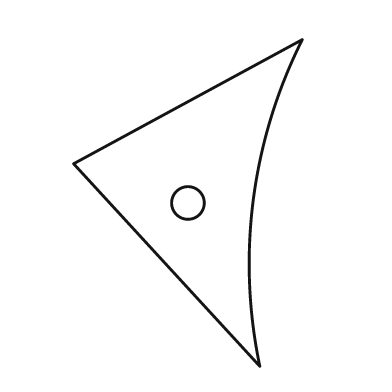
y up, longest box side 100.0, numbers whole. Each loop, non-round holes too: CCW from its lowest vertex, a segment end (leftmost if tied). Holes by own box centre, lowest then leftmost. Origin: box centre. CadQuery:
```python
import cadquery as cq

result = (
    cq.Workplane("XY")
    .moveTo(22.0, -50.0)
    .threePointArc((20.0, 1.0), (35.0, 50.0))
    .lineTo(-35.0, 12.0)
    .close()
    .moveTo(0.0, 0.0)
    .circle(5.0)
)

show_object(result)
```